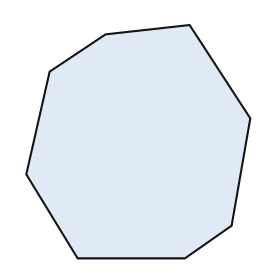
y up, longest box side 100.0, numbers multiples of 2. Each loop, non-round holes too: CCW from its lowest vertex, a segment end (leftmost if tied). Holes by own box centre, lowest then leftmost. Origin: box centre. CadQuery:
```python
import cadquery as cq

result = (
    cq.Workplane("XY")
    .moveTo(-26.0, -50.0)
    .lineTo(20.0, -50.0)
    .lineTo(40.0, -36.0)
    .lineTo(48.0, 10.0)
    .lineTo(22.0, 50.0)
    .lineTo(-14.0, 46.0)
    .lineTo(-38.0, 30.0)
    .lineTo(-48.0, -14.0)
    .close()
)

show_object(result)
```